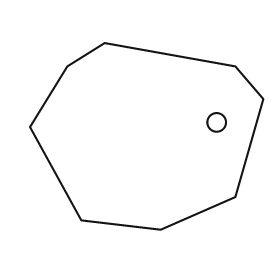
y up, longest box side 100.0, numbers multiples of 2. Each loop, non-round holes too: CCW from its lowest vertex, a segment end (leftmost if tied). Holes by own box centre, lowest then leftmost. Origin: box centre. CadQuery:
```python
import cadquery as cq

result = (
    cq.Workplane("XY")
    .moveTo(6.0, -40.0)
    .lineTo(38.0, -26.0)
    .lineTo(50.0, 16.0)
    .lineTo(38.0, 30.0)
    .lineTo(-18.0, 40.0)
    .lineTo(-34.0, 30.0)
    .lineTo(-50.0, 4.0)
    .lineTo(-28.0, -36.0)
    .close()
    .moveTo(30.0, 6.0)
    .circle(4.0)
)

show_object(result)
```